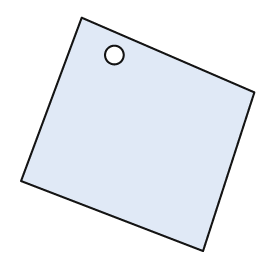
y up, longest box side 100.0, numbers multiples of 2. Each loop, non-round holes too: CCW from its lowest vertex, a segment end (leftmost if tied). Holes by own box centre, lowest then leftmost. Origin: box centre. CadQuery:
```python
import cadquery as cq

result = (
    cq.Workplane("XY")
    .moveTo(28.0, -50.0)
    .lineTo(50.0, 18.0)
    .lineTo(-24.0, 50.0)
    .lineTo(-50.0, -20.0)
    .close()
    .moveTo(-10.0, 34.0)
    .circle(4.0)
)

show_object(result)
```